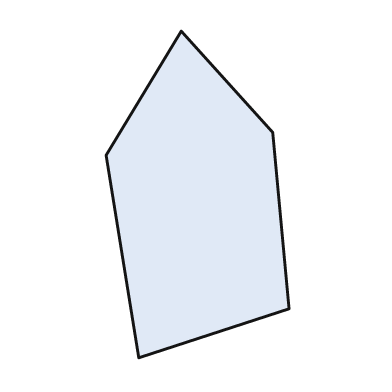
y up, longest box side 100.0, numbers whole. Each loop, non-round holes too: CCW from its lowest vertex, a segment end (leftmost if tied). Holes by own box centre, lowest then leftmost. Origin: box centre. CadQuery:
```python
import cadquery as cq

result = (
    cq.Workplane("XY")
    .moveTo(-18.0, -50.0)
    .lineTo(28.0, -35.0)
    .lineTo(23.0, 19.0)
    .lineTo(-5.0, 50.0)
    .lineTo(-28.0, 12.0)
    .close()
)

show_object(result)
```